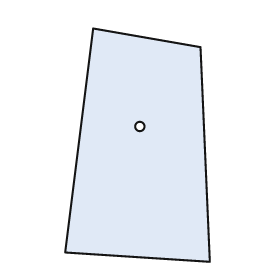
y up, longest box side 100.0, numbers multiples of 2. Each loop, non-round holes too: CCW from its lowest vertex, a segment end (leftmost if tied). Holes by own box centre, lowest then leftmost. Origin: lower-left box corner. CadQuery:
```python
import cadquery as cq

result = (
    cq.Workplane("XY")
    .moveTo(62.0, 0.0)
    .lineTo(58.0, 92.0)
    .lineTo(12.0, 100.0)
    .lineTo(0.0, 4.0)
    .close()
    .moveTo(32.0, 58.0)
    .circle(2.0)
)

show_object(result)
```